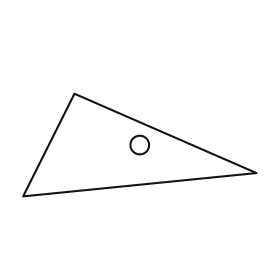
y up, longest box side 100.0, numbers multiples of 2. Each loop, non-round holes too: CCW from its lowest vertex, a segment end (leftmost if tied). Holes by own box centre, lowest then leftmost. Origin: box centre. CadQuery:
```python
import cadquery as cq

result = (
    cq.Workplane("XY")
    .moveTo(-50.0, -22.0)
    .lineTo(50.0, -12.0)
    .lineTo(-28.0, 22.0)
    .close()
    .moveTo(0.0, 0.0)
    .circle(4.0)
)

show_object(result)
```